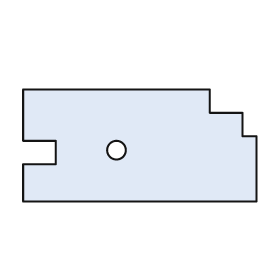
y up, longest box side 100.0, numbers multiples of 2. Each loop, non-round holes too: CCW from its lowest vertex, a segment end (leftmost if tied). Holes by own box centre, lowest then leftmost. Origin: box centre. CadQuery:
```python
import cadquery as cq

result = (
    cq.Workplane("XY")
    .moveTo(-50.0, -24.0)
    .lineTo(50.0, -24.0)
    .lineTo(50.0, 4.0)
    .lineTo(44.0, 4.0)
    .lineTo(44.0, 14.0)
    .lineTo(30.0, 14.0)
    .lineTo(30.0, 24.0)
    .lineTo(-50.0, 24.0)
    .lineTo(-50.0, 2.0)
    .lineTo(-36.0, 2.0)
    .lineTo(-36.0, -8.0)
    .lineTo(-50.0, -8.0)
    .close()
    .moveTo(-10.0, -2.0)
    .circle(4.0)
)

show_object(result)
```